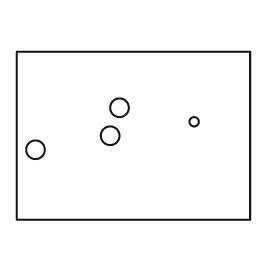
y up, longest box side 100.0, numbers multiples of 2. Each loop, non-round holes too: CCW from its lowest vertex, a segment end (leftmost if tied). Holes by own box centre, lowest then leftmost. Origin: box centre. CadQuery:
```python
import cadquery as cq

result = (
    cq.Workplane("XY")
    .moveTo(-50.0, -36.0)
    .lineTo(50.0, -36.0)
    .lineTo(50.0, 36.0)
    .lineTo(-50.0, 36.0)
    .close()
    .moveTo(-42.0, -6.0)
    .circle(4.0)
    .moveTo(-10.0, 0.0)
    .circle(4.0)
    .moveTo(26.0, 6.0)
    .circle(2.0)
    .moveTo(-6.0, 12.0)
    .circle(4.0)
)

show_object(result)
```